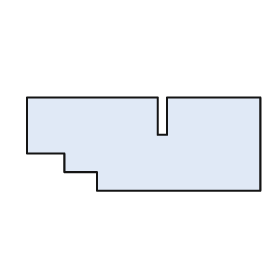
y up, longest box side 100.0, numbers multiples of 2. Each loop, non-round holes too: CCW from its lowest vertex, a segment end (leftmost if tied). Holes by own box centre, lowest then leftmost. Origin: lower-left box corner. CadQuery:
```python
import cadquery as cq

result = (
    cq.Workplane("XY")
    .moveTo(30.0, 0.0)
    .lineTo(100.0, 0.0)
    .lineTo(100.0, 40.0)
    .lineTo(60.0, 40.0)
    .lineTo(60.0, 24.0)
    .lineTo(56.0, 24.0)
    .lineTo(56.0, 40.0)
    .lineTo(0.0, 40.0)
    .lineTo(0.0, 16.0)
    .lineTo(16.0, 16.0)
    .lineTo(16.0, 8.0)
    .lineTo(30.0, 8.0)
    .close()
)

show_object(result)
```